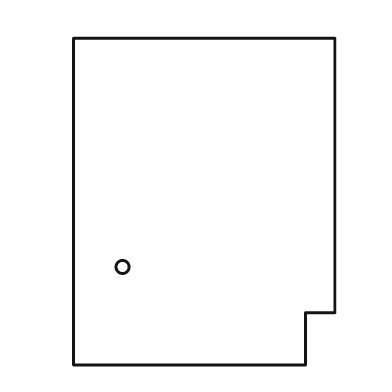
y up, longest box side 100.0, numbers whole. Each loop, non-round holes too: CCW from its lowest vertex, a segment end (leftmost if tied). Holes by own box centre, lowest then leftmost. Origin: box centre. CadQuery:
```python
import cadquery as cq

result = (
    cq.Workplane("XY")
    .moveTo(-40.0, -50.0)
    .lineTo(31.0, -50.0)
    .lineTo(31.0, -34.0)
    .lineTo(40.0, -34.0)
    .lineTo(40.0, 50.0)
    .lineTo(-40.0, 50.0)
    .close()
    .moveTo(-25.0, -20.0)
    .circle(2.0)
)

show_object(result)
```